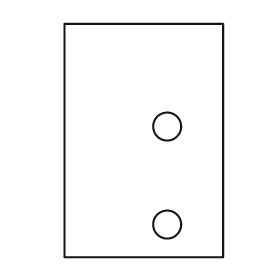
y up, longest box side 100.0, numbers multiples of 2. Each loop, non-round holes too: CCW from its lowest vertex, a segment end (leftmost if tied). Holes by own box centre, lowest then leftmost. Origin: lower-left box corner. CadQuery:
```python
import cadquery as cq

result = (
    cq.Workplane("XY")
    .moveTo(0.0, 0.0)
    .lineTo(68.0, 0.0)
    .lineTo(68.0, 100.0)
    .lineTo(0.0, 100.0)
    .close()
    .moveTo(44.0, 14.0)
    .circle(6.0)
    .moveTo(44.0, 56.0)
    .circle(6.0)
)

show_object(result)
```